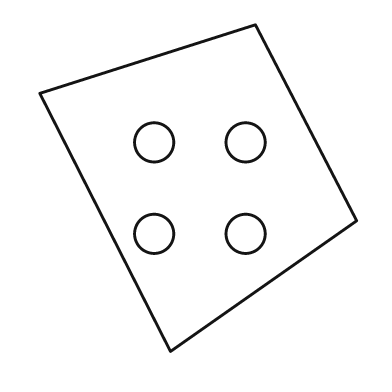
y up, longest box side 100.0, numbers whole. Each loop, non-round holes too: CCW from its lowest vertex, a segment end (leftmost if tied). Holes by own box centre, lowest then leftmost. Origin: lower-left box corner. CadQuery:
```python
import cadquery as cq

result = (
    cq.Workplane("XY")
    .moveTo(40.0, 0.0)
    .lineTo(97.0, 40.0)
    .lineTo(66.0, 100.0)
    .lineTo(0.0, 79.0)
    .close()
    .moveTo(35.0, 36.0)
    .circle(6.0)
    .moveTo(63.0, 36.0)
    .circle(6.0)
    .moveTo(35.0, 64.0)
    .circle(6.0)
    .moveTo(63.0, 64.0)
    .circle(6.0)
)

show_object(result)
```